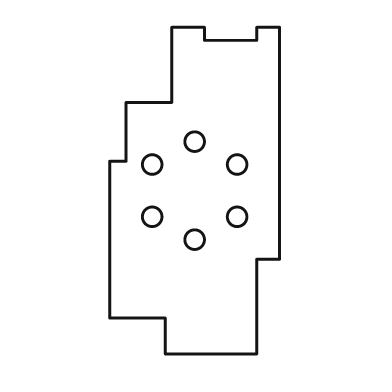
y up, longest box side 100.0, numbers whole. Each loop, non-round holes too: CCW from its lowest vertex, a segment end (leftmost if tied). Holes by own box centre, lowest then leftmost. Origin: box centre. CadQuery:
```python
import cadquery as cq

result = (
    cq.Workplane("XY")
    .moveTo(-9.0, -50.0)
    .lineTo(19.0, -50.0)
    .lineTo(19.0, -21.0)
    .lineTo(26.0, -21.0)
    .lineTo(26.0, 50.0)
    .lineTo(19.0, 50.0)
    .lineTo(19.0, 46.0)
    .lineTo(3.0, 46.0)
    .lineTo(3.0, 50.0)
    .lineTo(-7.0, 50.0)
    .lineTo(-7.0, 27.0)
    .lineTo(-21.0, 27.0)
    .lineTo(-21.0, 9.0)
    .lineTo(-26.0, 9.0)
    .lineTo(-26.0, -39.0)
    .lineTo(-9.0, -39.0)
    .close()
    .moveTo(0.0, -15.0)
    .circle(3.0)
    .moveTo(-13.0, -8.0)
    .circle(3.0)
    .moveTo(13.0, -8.0)
    .circle(3.0)
    .moveTo(-13.0, 8.0)
    .circle(3.0)
    .moveTo(13.0, 8.0)
    .circle(3.0)
    .moveTo(0.0, 15.0)
    .circle(3.0)
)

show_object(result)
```